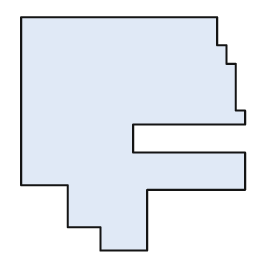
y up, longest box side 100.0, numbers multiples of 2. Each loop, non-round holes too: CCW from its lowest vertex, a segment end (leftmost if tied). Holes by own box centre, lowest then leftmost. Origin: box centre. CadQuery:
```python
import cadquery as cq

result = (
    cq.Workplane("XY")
    .moveTo(-14.0, -50.0)
    .lineTo(6.0, -50.0)
    .lineTo(6.0, -24.0)
    .lineTo(48.0, -24.0)
    .lineTo(48.0, -8.0)
    .lineTo(0.0, -8.0)
    .lineTo(0.0, 4.0)
    .lineTo(48.0, 4.0)
    .lineTo(48.0, 10.0)
    .lineTo(44.0, 10.0)
    .lineTo(44.0, 30.0)
    .lineTo(40.0, 30.0)
    .lineTo(40.0, 38.0)
    .lineTo(36.0, 38.0)
    .lineTo(36.0, 50.0)
    .lineTo(-48.0, 50.0)
    .lineTo(-48.0, -22.0)
    .lineTo(-28.0, -22.0)
    .lineTo(-28.0, -40.0)
    .lineTo(-14.0, -40.0)
    .close()
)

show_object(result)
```